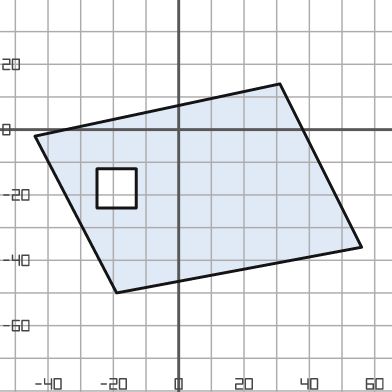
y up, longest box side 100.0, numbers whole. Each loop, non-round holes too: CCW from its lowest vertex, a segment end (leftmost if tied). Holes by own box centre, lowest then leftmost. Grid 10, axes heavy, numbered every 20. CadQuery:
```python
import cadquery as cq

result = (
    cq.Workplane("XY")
    .moveTo(-19.0, -50.0)
    .lineTo(56.0, -36.0)
    .lineTo(31.0, 14.0)
    .lineTo(-44.0, -2.0)
    .close()
    .moveTo(-25.0, -24.0)
    .lineTo(-13.0, -24.0)
    .lineTo(-13.0, -12.0)
    .lineTo(-25.0, -12.0)
    .close()
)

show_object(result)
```